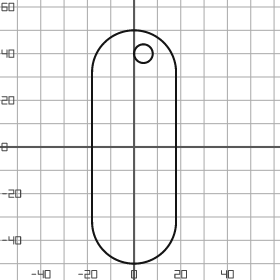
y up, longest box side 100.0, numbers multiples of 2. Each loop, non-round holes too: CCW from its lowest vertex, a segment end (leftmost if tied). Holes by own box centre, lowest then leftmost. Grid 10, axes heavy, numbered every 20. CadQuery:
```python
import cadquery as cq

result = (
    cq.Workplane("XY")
    .moveTo(-18.0, -32.0)
    .threePointArc((0.0, -50.0), (18.0, -32.0))
    .lineTo(18.0, 32.0)
    .threePointArc((0.0, 50.0), (-18.0, 32.0))
    .close()
    .moveTo(4.0, 40.0)
    .circle(4.0)
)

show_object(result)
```